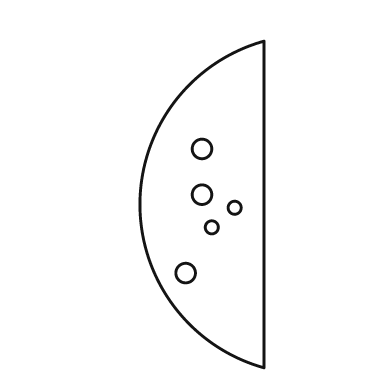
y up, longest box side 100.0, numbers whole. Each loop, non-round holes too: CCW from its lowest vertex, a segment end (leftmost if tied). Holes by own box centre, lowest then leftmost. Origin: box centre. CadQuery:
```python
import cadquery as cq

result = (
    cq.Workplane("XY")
    .moveTo(19.0, -50.0)
    .lineTo(19.0, 50.0)
    .threePointArc((-19.0, 0.0), (19.0, -50.0))
    .close()
    .moveTo(-5.0, -21.0)
    .circle(3.0)
    .moveTo(3.0, -7.0)
    .circle(2.0)
    .moveTo(10.0, -1.0)
    .circle(2.0)
    .moveTo(0.0, 3.0)
    .circle(3.0)
    .moveTo(0.0, 17.0)
    .circle(3.0)
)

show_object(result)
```